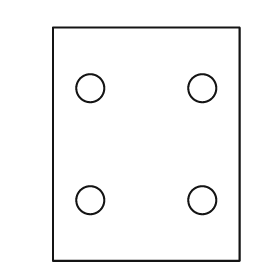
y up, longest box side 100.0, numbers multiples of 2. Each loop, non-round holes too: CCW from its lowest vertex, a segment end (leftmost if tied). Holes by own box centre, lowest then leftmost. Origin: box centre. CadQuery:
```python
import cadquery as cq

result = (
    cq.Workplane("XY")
    .moveTo(-40.0, -50.0)
    .lineTo(40.0, -50.0)
    .lineTo(40.0, 50.0)
    .lineTo(-40.0, 50.0)
    .close()
    .moveTo(-24.0, -24.0)
    .circle(6.0)
    .moveTo(24.0, -24.0)
    .circle(6.0)
    .moveTo(-24.0, 24.0)
    .circle(6.0)
    .moveTo(24.0, 24.0)
    .circle(6.0)
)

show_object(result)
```